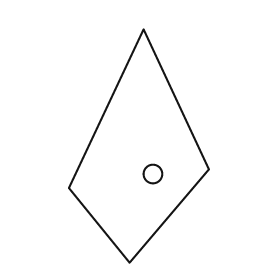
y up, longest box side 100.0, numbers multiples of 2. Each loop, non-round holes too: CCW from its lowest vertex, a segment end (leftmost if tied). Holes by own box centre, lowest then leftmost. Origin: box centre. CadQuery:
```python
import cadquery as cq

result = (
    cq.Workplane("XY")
    .moveTo(-4.0, -50.0)
    .lineTo(30.0, -10.0)
    .lineTo(2.0, 50.0)
    .lineTo(-30.0, -18.0)
    .close()
    .moveTo(6.0, -12.0)
    .circle(4.0)
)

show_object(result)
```